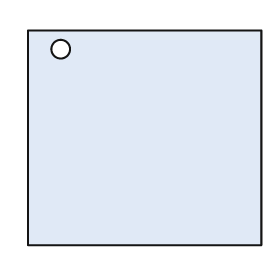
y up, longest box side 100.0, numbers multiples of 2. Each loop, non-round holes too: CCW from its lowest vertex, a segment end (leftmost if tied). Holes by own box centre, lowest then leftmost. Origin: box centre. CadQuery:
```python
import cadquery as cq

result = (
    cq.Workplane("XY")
    .moveTo(-50.0, -46.0)
    .lineTo(50.0, -46.0)
    .lineTo(50.0, 46.0)
    .lineTo(-50.0, 46.0)
    .close()
    .moveTo(-36.0, 38.0)
    .circle(4.0)
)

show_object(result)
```